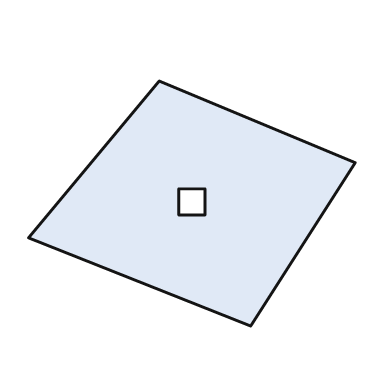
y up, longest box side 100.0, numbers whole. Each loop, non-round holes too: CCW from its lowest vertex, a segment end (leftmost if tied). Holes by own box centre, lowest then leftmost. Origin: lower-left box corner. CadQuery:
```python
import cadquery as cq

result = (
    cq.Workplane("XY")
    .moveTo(68.0, 0.0)
    .lineTo(100.0, 50.0)
    .lineTo(40.0, 75.0)
    .lineTo(0.0, 27.0)
    .close()
    .moveTo(46.0, 34.0)
    .lineTo(54.0, 34.0)
    .lineTo(54.0, 42.0)
    .lineTo(46.0, 42.0)
    .close()
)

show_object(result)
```